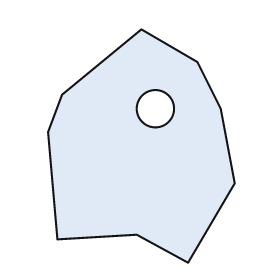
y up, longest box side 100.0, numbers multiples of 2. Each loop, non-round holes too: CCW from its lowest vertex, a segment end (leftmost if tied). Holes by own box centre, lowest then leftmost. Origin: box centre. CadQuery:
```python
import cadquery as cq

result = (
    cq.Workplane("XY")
    .moveTo(20.0, -50.0)
    .lineTo(40.0, -16.0)
    .lineTo(34.0, 16.0)
    .lineTo(24.0, 36.0)
    .lineTo(0.0, 50.0)
    .lineTo(-34.0, 22.0)
    .lineTo(-40.0, 6.0)
    .lineTo(-36.0, -40.0)
    .lineTo(-2.0, -38.0)
    .close()
    .moveTo(6.0, 16.0)
    .circle(8.0)
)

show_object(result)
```